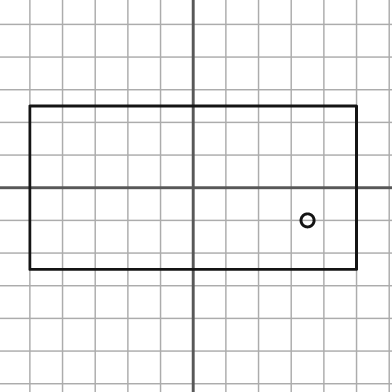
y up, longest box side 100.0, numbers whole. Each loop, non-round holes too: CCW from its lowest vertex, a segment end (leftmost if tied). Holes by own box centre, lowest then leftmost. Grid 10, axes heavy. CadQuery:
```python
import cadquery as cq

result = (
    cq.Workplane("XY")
    .moveTo(-50.0, -25.0)
    .lineTo(50.0, -25.0)
    .lineTo(50.0, 25.0)
    .lineTo(-50.0, 25.0)
    .close()
    .moveTo(35.0, -10.0)
    .circle(2.0)
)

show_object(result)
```